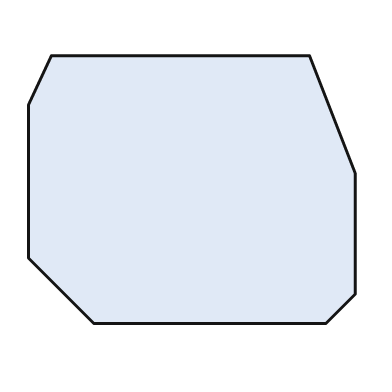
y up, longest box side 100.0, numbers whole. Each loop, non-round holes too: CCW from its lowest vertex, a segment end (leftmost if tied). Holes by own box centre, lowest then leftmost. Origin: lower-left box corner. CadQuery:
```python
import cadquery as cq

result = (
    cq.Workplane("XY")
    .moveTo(20.0, 0.0)
    .lineTo(91.0, 0.0)
    .lineTo(100.0, 9.0)
    .lineTo(100.0, 46.0)
    .lineTo(86.0, 82.0)
    .lineTo(7.0, 82.0)
    .lineTo(0.0, 67.0)
    .lineTo(0.0, 20.0)
    .close()
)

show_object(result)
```